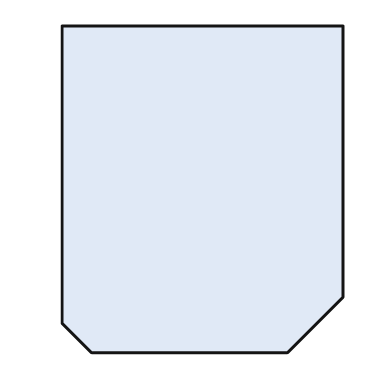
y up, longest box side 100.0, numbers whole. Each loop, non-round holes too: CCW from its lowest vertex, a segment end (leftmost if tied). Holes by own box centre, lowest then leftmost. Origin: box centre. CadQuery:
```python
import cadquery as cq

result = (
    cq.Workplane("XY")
    .moveTo(-34.0, -50.0)
    .lineTo(26.0, -50.0)
    .lineTo(43.0, -33.0)
    .lineTo(43.0, 50.0)
    .lineTo(-43.0, 50.0)
    .lineTo(-43.0, -41.0)
    .close()
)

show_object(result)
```